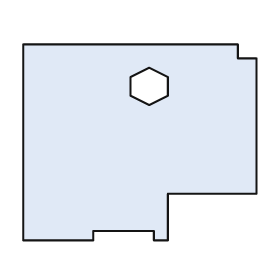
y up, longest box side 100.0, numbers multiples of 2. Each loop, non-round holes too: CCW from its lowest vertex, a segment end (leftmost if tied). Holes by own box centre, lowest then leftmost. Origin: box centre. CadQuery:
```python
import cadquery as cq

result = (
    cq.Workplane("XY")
    .moveTo(-50.0, -42.0)
    .lineTo(-20.0, -42.0)
    .lineTo(-20.0, -38.0)
    .lineTo(6.0, -38.0)
    .lineTo(6.0, -42.0)
    .lineTo(12.0, -42.0)
    .lineTo(12.0, -22.0)
    .lineTo(50.0, -22.0)
    .lineTo(50.0, 36.0)
    .lineTo(42.0, 36.0)
    .lineTo(42.0, 42.0)
    .lineTo(-50.0, 42.0)
    .close()
    .moveTo(4.0, 16.0)
    .lineTo(12.0, 20.0)
    .lineTo(12.0, 28.0)
    .lineTo(4.0, 32.0)
    .lineTo(-4.0, 28.0)
    .lineTo(-4.0, 20.0)
    .close()
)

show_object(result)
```